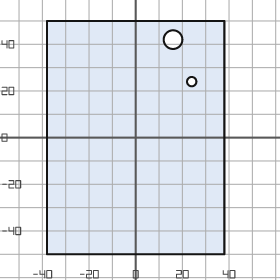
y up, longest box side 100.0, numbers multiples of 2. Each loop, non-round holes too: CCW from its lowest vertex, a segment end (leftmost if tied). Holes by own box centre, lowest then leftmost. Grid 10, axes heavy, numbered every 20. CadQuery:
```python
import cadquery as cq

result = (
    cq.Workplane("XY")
    .moveTo(-38.0, -50.0)
    .lineTo(38.0, -50.0)
    .lineTo(38.0, 50.0)
    .lineTo(-38.0, 50.0)
    .close()
    .moveTo(24.0, 24.0)
    .circle(2.0)
    .moveTo(16.0, 42.0)
    .circle(4.0)
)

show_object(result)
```